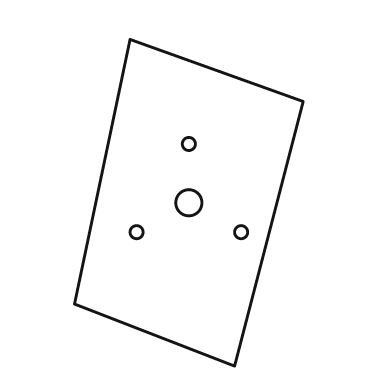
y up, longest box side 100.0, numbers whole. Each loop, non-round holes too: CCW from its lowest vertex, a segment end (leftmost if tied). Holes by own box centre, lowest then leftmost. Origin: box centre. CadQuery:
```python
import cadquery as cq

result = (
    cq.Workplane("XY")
    .moveTo(14.0, -50.0)
    .lineTo(35.0, 31.0)
    .lineTo(-18.0, 50.0)
    .lineTo(-35.0, -31.0)
    .close()
    .moveTo(-16.0, -9.0)
    .circle(2.0)
    .moveTo(16.0, -9.0)
    .circle(2.0)
    .moveTo(0.0, 0.0)
    .circle(4.0)
    .moveTo(0.0, 18.0)
    .circle(2.0)
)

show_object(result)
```